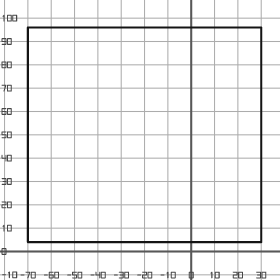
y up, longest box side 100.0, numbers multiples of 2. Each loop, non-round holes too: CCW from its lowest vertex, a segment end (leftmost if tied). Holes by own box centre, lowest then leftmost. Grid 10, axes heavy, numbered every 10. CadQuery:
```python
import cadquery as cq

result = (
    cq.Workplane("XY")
    .moveTo(-70.0, 4.0)
    .lineTo(30.0, 4.0)
    .lineTo(30.0, 96.0)
    .lineTo(-70.0, 96.0)
    .close()
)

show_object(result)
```